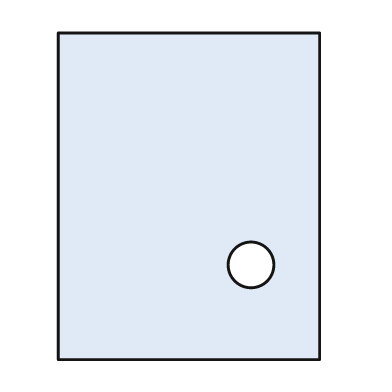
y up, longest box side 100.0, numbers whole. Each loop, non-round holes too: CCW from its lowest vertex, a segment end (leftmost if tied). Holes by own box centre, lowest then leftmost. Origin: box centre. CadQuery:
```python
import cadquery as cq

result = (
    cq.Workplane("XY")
    .moveTo(-40.0, -50.0)
    .lineTo(40.0, -50.0)
    .lineTo(40.0, 50.0)
    .lineTo(-40.0, 50.0)
    .close()
    .moveTo(19.0, -21.0)
    .circle(7.0)
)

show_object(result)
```